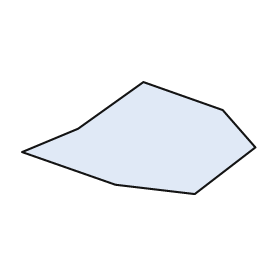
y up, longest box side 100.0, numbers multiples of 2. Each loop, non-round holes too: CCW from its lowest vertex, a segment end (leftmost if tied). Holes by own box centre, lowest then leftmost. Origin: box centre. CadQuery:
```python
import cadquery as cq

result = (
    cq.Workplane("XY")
    .moveTo(24.0, -24.0)
    .lineTo(50.0, -4.0)
    .lineTo(36.0, 12.0)
    .lineTo(2.0, 24.0)
    .lineTo(-26.0, 4.0)
    .lineTo(-50.0, -6.0)
    .lineTo(-10.0, -20.0)
    .close()
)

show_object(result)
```